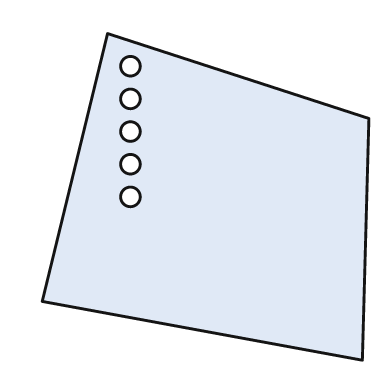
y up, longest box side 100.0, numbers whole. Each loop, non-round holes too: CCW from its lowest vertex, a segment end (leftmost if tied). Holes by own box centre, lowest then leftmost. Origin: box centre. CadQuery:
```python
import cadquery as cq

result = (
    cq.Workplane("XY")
    .moveTo(48.0, -50.0)
    .lineTo(50.0, 24.0)
    .lineTo(-30.0, 50.0)
    .lineTo(-50.0, -32.0)
    .close()
    .moveTo(-23.0, 0.0)
    .circle(3.0)
    .moveTo(-23.0, 10.0)
    .circle(3.0)
    .moveTo(-23.0, 20.0)
    .circle(3.0)
    .moveTo(-23.0, 30.0)
    .circle(3.0)
    .moveTo(-23.0, 40.0)
    .circle(3.0)
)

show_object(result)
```